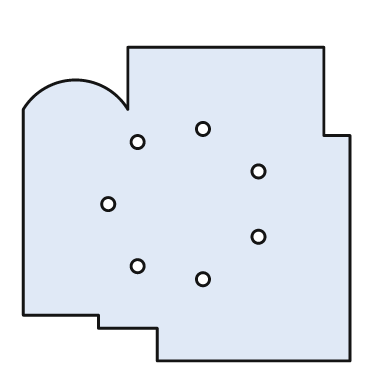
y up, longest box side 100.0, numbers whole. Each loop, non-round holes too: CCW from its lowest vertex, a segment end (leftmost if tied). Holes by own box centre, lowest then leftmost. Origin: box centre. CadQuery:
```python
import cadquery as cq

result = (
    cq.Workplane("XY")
    .moveTo(-9.0, -48.0)
    .lineTo(50.0, -48.0)
    .lineTo(50.0, 21.0)
    .lineTo(42.0, 21.0)
    .lineTo(42.0, 48.0)
    .lineTo(-18.0, 48.0)
    .lineTo(-18.0, 29.0)
    .threePointArc((-34.0, 38.0), (-50.0, 29.0))
    .lineTo(-50.0, -34.0)
    .lineTo(-27.0, -34.0)
    .lineTo(-27.0, -38.0)
    .lineTo(-9.0, -38.0)
    .close()
    .moveTo(5.0, -23.0)
    .circle(2.0)
    .moveTo(-15.0, -19.0)
    .circle(2.0)
    .moveTo(22.0, -10.0)
    .circle(2.0)
    .moveTo(-24.0, 0.0)
    .circle(2.0)
    .moveTo(22.0, 10.0)
    .circle(2.0)
    .moveTo(-15.0, 19.0)
    .circle(2.0)
    .moveTo(5.0, 23.0)
    .circle(2.0)
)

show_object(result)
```